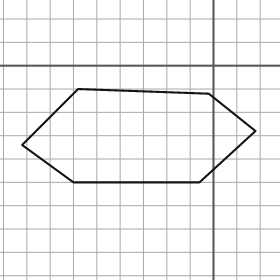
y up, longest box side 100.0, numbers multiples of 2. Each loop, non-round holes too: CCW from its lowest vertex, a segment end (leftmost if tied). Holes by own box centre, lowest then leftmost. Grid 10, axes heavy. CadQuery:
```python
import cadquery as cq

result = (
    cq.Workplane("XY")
    .moveTo(-60.0, -50.0)
    .lineTo(-6.0, -50.0)
    .lineTo(18.0, -28.0)
    .lineTo(-2.0, -12.0)
    .lineTo(-58.0, -10.0)
    .lineTo(-82.0, -34.0)
    .close()
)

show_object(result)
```